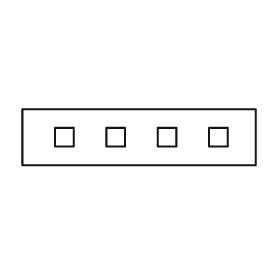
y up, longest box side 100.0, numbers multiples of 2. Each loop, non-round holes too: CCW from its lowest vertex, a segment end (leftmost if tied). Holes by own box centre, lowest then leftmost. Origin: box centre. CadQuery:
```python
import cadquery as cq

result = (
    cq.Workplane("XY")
    .moveTo(-50.0, -12.0)
    .lineTo(50.0, -12.0)
    .lineTo(50.0, 12.0)
    .lineTo(-50.0, 12.0)
    .close()
    .moveTo(-36.0, -4.0)
    .lineTo(-28.0, -4.0)
    .lineTo(-28.0, 4.0)
    .lineTo(-36.0, 4.0)
    .close()
    .moveTo(-14.0, -4.0)
    .lineTo(-6.0, -4.0)
    .lineTo(-6.0, 4.0)
    .lineTo(-14.0, 4.0)
    .close()
    .moveTo(8.0, -4.0)
    .lineTo(16.0, -4.0)
    .lineTo(16.0, 4.0)
    .lineTo(8.0, 4.0)
    .close()
    .moveTo(30.0, -4.0)
    .lineTo(38.0, -4.0)
    .lineTo(38.0, 4.0)
    .lineTo(30.0, 4.0)
    .close()
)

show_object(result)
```